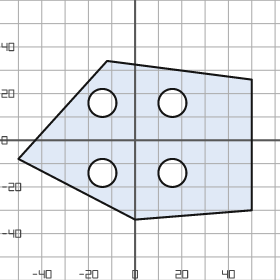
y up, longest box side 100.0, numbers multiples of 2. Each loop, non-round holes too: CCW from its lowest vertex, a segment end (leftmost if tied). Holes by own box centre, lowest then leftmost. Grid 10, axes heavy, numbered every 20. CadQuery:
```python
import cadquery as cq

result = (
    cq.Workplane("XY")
    .moveTo(0.0, -34.0)
    .lineTo(50.0, -30.0)
    .lineTo(50.0, 26.0)
    .lineTo(-12.0, 34.0)
    .lineTo(-50.0, -8.0)
    .close()
    .moveTo(-14.0, -14.0)
    .circle(6.0)
    .moveTo(16.0, -14.0)
    .circle(6.0)
    .moveTo(-14.0, 16.0)
    .circle(6.0)
    .moveTo(16.0, 16.0)
    .circle(6.0)
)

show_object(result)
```